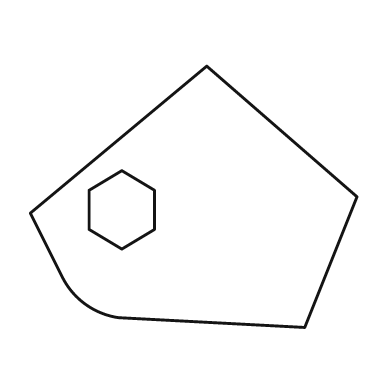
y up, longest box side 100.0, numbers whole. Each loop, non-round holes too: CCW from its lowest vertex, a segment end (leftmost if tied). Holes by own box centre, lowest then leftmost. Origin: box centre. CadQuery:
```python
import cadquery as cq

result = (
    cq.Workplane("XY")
    .moveTo(34.0, -40.0)
    .lineTo(50.0, 0.0)
    .lineTo(4.0, 40.0)
    .lineTo(-50.0, -5.0)
    .lineTo(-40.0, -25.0)
    .threePointArc((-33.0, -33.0), (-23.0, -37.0))
    .close()
    .moveTo(-22.0, -16.0)
    .lineTo(-12.0, -10.0)
    .lineTo(-12.0, 2.0)
    .lineTo(-22.0, 8.0)
    .lineTo(-32.0, 2.0)
    .lineTo(-32.0, -10.0)
    .close()
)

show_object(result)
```